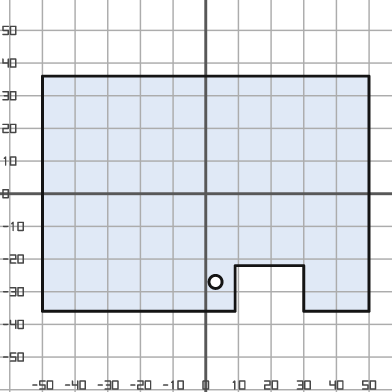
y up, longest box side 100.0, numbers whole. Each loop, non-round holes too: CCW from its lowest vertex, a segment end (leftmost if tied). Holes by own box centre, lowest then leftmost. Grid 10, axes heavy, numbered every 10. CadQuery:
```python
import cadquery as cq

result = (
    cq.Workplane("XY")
    .moveTo(-50.0, -36.0)
    .lineTo(9.0, -36.0)
    .lineTo(9.0, -22.0)
    .lineTo(30.0, -22.0)
    .lineTo(30.0, -36.0)
    .lineTo(50.0, -36.0)
    .lineTo(50.0, 36.0)
    .lineTo(-50.0, 36.0)
    .close()
    .moveTo(3.0, -27.0)
    .circle(2.0)
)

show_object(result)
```